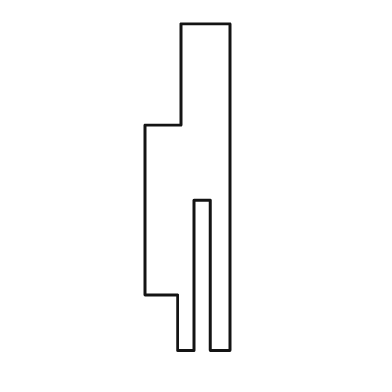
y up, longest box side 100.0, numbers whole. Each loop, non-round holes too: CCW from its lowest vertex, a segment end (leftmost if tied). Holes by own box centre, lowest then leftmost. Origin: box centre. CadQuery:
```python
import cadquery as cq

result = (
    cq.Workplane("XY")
    .moveTo(-3.0, -50.0)
    .lineTo(2.0, -50.0)
    .lineTo(2.0, -4.0)
    .lineTo(7.0, -4.0)
    .lineTo(7.0, -50.0)
    .lineTo(13.0, -50.0)
    .lineTo(13.0, 50.0)
    .lineTo(-2.0, 50.0)
    .lineTo(-2.0, 19.0)
    .lineTo(-13.0, 19.0)
    .lineTo(-13.0, -33.0)
    .lineTo(-3.0, -33.0)
    .close()
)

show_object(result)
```